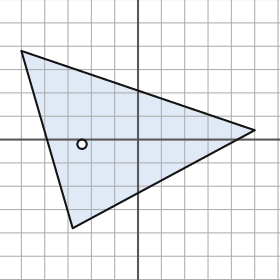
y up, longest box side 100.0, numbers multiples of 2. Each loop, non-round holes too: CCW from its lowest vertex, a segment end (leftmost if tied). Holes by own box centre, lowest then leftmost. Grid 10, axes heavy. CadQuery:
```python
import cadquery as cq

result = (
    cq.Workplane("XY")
    .moveTo(-28.0, -38.0)
    .lineTo(50.0, 4.0)
    .lineTo(-50.0, 38.0)
    .close()
    .moveTo(-24.0, -2.0)
    .circle(2.0)
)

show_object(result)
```